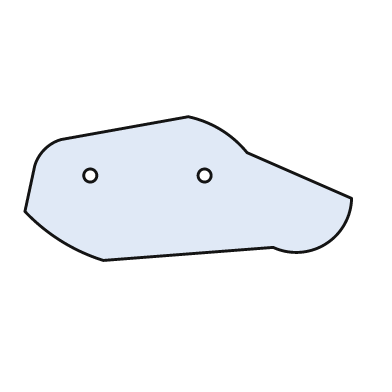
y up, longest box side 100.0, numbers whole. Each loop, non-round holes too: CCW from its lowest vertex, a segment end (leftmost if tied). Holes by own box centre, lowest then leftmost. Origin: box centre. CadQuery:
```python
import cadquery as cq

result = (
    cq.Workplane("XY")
    .moveTo(-26.0, -22.0)
    .lineTo(26.0, -18.0)
    .threePointArc((42.0, -17.0), (50.0, -3.0))
    .lineTo(18.0, 11.0)
    .threePointArc((10.0, 18.0), (0.0, 22.0))
    .lineTo(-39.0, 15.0)
    .threePointArc((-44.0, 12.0), (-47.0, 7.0))
    .lineTo(-50.0, -7.0)
    .threePointArc((-39.0, -16.0), (-26.0, -22.0))
    .close()
    .moveTo(-30.0, 4.0)
    .circle(2.0)
    .moveTo(5.0, 4.0)
    .circle(2.0)
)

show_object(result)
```